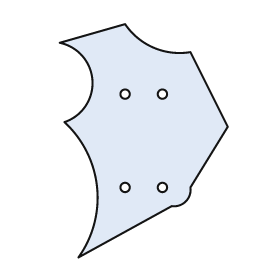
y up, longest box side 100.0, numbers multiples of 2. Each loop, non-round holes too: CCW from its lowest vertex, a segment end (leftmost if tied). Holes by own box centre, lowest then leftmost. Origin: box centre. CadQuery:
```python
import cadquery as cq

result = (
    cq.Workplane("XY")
    .moveTo(-28.0, -50.0)
    .lineTo(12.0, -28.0)
    .threePointArc((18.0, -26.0), (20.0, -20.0))
    .lineTo(36.0, 6.0)
    .lineTo(20.0, 38.0)
    .threePointArc((4.0, 40.0), (-8.0, 50.0))
    .lineTo(-36.0, 42.0)
    .threePointArc((-22.0, 26.0), (-34.0, 8.0))
    .threePointArc((-20.0, -20.0), (-28.0, -50.0))
    .close()
    .moveTo(-8.0, -20.0)
    .circle(2.0)
    .moveTo(8.0, -20.0)
    .circle(2.0)
    .moveTo(-8.0, 20.0)
    .circle(2.0)
    .moveTo(8.0, 20.0)
    .circle(2.0)
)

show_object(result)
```